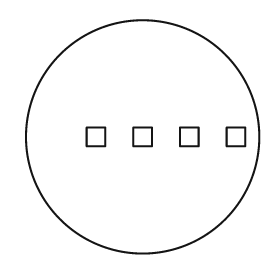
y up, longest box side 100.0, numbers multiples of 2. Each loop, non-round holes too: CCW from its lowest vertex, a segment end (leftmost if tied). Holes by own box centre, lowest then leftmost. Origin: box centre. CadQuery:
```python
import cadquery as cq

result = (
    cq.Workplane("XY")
    .moveTo(0.0, 0.0)
    .circle(50.0)
    .moveTo(-24.0, -4.0)
    .lineTo(-16.0, -4.0)
    .lineTo(-16.0, 4.0)
    .lineTo(-24.0, 4.0)
    .close()
    .moveTo(-4.0, -4.0)
    .lineTo(4.0, -4.0)
    .lineTo(4.0, 4.0)
    .lineTo(-4.0, 4.0)
    .close()
    .moveTo(16.0, -4.0)
    .lineTo(24.0, -4.0)
    .lineTo(24.0, 4.0)
    .lineTo(16.0, 4.0)
    .close()
    .moveTo(36.0, -4.0)
    .lineTo(44.0, -4.0)
    .lineTo(44.0, 4.0)
    .lineTo(36.0, 4.0)
    .close()
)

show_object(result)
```